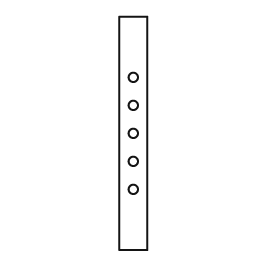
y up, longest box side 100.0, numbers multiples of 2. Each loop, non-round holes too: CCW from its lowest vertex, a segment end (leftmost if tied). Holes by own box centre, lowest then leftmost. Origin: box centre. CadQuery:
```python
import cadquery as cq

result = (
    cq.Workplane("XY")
    .moveTo(-6.0, -50.0)
    .lineTo(6.0, -50.0)
    .lineTo(6.0, 50.0)
    .lineTo(-6.0, 50.0)
    .close()
    .moveTo(0.0, -24.0)
    .circle(2.0)
    .moveTo(0.0, -12.0)
    .circle(2.0)
    .moveTo(0.0, 0.0)
    .circle(2.0)
    .moveTo(0.0, 12.0)
    .circle(2.0)
    .moveTo(0.0, 24.0)
    .circle(2.0)
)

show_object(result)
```